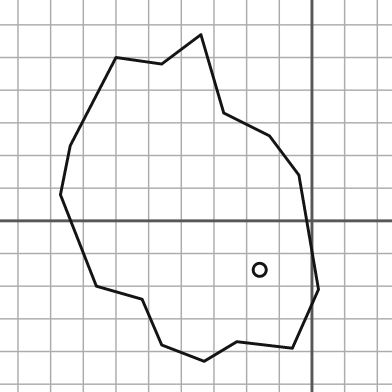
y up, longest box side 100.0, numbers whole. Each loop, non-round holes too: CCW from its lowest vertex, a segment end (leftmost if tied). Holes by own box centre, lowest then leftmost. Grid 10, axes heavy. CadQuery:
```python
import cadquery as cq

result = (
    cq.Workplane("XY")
    .moveTo(-33.0, -43.0)
    .lineTo(-23.0, -37.0)
    .lineTo(-6.0, -39.0)
    .lineTo(2.0, -21.0)
    .lineTo(-4.0, 14.0)
    .lineTo(-13.0, 26.0)
    .lineTo(-27.0, 33.0)
    .lineTo(-34.0, 57.0)
    .lineTo(-46.0, 48.0)
    .lineTo(-60.0, 50.0)
    .lineTo(-74.0, 23.0)
    .lineTo(-77.0, 8.0)
    .lineTo(-66.0, -20.0)
    .lineTo(-52.0, -24.0)
    .lineTo(-46.0, -38.0)
    .close()
    .moveTo(-16.0, -15.0)
    .circle(2.0)
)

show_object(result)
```